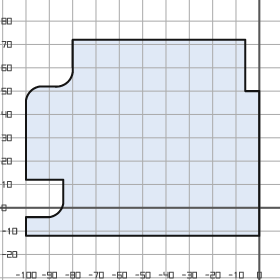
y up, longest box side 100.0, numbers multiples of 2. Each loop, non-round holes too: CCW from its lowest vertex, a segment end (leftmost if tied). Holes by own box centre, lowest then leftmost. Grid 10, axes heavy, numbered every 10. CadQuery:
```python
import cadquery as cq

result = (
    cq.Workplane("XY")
    .moveTo(-100.0, -12.0)
    .lineTo(0.0, -12.0)
    .lineTo(0.0, 50.0)
    .lineTo(-6.0, 50.0)
    .lineTo(-6.0, 72.0)
    .lineTo(-80.0, 72.0)
    .lineTo(-80.0, 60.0)
    .threePointArc((-82.0, 54.0), (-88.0, 52.0))
    .lineTo(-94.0, 52.0)
    .threePointArc((-98.0, 50.0), (-100.0, 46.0))
    .lineTo(-100.0, 12.0)
    .lineTo(-84.0, 12.0)
    .lineTo(-84.0, 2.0)
    .threePointArc((-86.0, -2.0), (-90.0, -4.0))
    .lineTo(-100.0, -4.0)
    .close()
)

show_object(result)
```